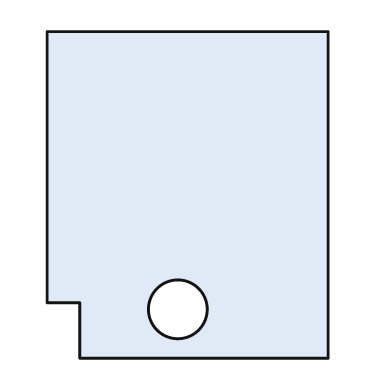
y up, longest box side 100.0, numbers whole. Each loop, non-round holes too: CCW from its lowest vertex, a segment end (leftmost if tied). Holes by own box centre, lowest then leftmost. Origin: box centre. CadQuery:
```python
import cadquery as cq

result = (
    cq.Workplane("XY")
    .moveTo(-33.0, -50.0)
    .lineTo(43.0, -50.0)
    .lineTo(43.0, 50.0)
    .lineTo(-43.0, 50.0)
    .lineTo(-43.0, -33.0)
    .lineTo(-33.0, -33.0)
    .close()
    .moveTo(-3.0, -35.0)
    .circle(9.0)
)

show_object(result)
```